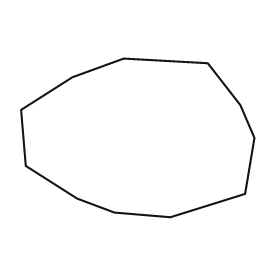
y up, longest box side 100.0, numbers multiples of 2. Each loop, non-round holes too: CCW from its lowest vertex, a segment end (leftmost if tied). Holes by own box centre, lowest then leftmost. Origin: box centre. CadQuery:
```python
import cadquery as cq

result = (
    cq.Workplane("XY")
    .moveTo(14.0, -34.0)
    .lineTo(46.0, -24.0)
    .lineTo(50.0, 0.0)
    .lineTo(44.0, 14.0)
    .lineTo(30.0, 32.0)
    .lineTo(-6.0, 34.0)
    .lineTo(-28.0, 26.0)
    .lineTo(-50.0, 12.0)
    .lineTo(-48.0, -12.0)
    .lineTo(-26.0, -26.0)
    .lineTo(-10.0, -32.0)
    .close()
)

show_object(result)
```